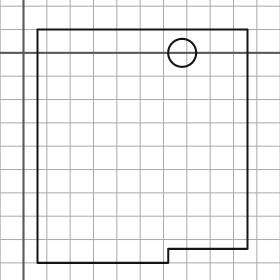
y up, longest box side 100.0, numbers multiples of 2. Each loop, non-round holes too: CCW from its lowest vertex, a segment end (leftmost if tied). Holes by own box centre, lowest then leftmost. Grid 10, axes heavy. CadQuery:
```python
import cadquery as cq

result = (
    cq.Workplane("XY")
    .moveTo(6.0, -90.0)
    .lineTo(62.0, -90.0)
    .lineTo(62.0, -84.0)
    .lineTo(96.0, -84.0)
    .lineTo(96.0, 10.0)
    .lineTo(6.0, 10.0)
    .close()
    .moveTo(68.0, 0.0)
    .circle(6.0)
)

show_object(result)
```